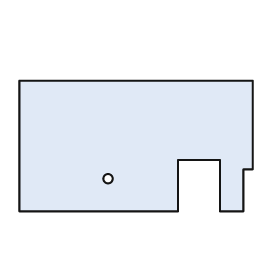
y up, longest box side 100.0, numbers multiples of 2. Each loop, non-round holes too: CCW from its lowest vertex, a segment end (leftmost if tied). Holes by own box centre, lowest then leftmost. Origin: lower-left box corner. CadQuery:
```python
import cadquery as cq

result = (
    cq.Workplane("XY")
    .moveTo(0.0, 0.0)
    .lineTo(68.0, 0.0)
    .lineTo(68.0, 22.0)
    .lineTo(86.0, 22.0)
    .lineTo(86.0, 0.0)
    .lineTo(96.0, 0.0)
    .lineTo(96.0, 18.0)
    .lineTo(100.0, 18.0)
    .lineTo(100.0, 56.0)
    .lineTo(0.0, 56.0)
    .close()
    .moveTo(38.0, 14.0)
    .circle(2.0)
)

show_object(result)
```